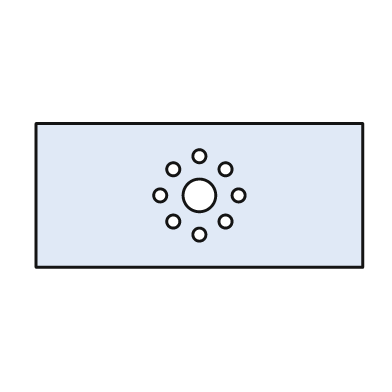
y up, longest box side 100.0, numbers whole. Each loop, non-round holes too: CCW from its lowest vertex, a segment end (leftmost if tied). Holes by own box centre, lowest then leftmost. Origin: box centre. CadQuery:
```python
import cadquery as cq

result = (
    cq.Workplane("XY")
    .moveTo(-50.0, -22.0)
    .lineTo(50.0, -22.0)
    .lineTo(50.0, 22.0)
    .lineTo(-50.0, 22.0)
    .close()
    .moveTo(0.0, -12.0)
    .circle(2.0)
    .moveTo(-8.0, -8.0)
    .circle(2.0)
    .moveTo(8.0, -8.0)
    .circle(2.0)
    .moveTo(-12.0, 0.0)
    .circle(2.0)
    .moveTo(0.0, 0.0)
    .circle(5.0)
    .moveTo(12.0, 0.0)
    .circle(2.0)
    .moveTo(-8.0, 8.0)
    .circle(2.0)
    .moveTo(8.0, 8.0)
    .circle(2.0)
    .moveTo(0.0, 12.0)
    .circle(2.0)
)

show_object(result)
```